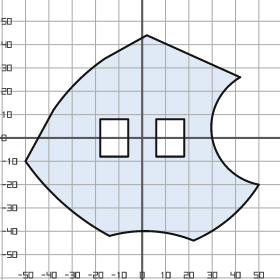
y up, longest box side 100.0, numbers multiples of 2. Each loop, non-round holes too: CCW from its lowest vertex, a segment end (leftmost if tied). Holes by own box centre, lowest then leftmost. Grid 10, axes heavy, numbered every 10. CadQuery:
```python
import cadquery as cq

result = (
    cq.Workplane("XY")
    .moveTo(22.0, -44.0)
    .threePointArc((38.0, -34.0), (50.0, -20.0))
    .threePointArc((30.0, 0.0), (42.0, 26.0))
    .lineTo(2.0, 44.0)
    .lineTo(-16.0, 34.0)
    .threePointArc((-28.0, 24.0), (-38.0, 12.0))
    .lineTo(-50.0, -10.0)
    .threePointArc((-34.0, -28.0), (-14.0, -42.0))
    .threePointArc((4.0, -40.0), (22.0, -44.0))
    .close()
    .moveTo(-18.0, -8.0)
    .lineTo(-6.0, -8.0)
    .lineTo(-6.0, 8.0)
    .lineTo(-18.0, 8.0)
    .close()
    .moveTo(6.0, -8.0)
    .lineTo(18.0, -8.0)
    .lineTo(18.0, 8.0)
    .lineTo(6.0, 8.0)
    .close()
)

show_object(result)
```